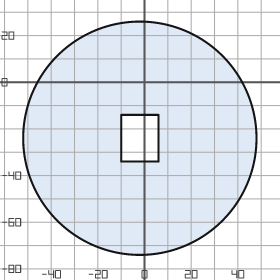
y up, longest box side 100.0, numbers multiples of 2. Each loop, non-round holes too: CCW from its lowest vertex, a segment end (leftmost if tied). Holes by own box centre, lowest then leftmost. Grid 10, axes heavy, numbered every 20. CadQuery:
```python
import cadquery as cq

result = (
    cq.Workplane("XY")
    .moveTo(-2.0, -24.0)
    .circle(50.0)
    .moveTo(-10.0, -34.0)
    .lineTo(6.0, -34.0)
    .lineTo(6.0, -14.0)
    .lineTo(-10.0, -14.0)
    .close()
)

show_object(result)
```